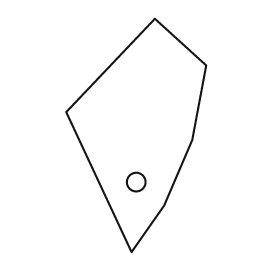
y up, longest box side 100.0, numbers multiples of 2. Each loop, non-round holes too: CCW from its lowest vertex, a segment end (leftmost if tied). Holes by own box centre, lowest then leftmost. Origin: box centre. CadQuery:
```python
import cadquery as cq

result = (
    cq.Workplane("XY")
    .moveTo(-2.0, -50.0)
    .lineTo(12.0, -30.0)
    .lineTo(24.0, -2.0)
    .lineTo(30.0, 30.0)
    .lineTo(8.0, 50.0)
    .lineTo(-30.0, 10.0)
    .close()
    .moveTo(0.0, -20.0)
    .circle(4.0)
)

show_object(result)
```